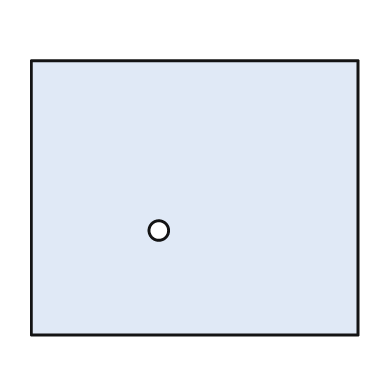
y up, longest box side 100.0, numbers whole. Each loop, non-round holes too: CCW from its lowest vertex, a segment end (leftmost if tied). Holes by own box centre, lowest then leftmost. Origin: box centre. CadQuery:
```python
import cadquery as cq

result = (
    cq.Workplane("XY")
    .moveTo(-50.0, -42.0)
    .lineTo(50.0, -42.0)
    .lineTo(50.0, 42.0)
    .lineTo(-50.0, 42.0)
    .close()
    .moveTo(-11.0, -10.0)
    .circle(3.0)
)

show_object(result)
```